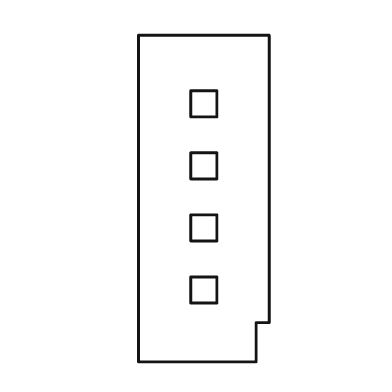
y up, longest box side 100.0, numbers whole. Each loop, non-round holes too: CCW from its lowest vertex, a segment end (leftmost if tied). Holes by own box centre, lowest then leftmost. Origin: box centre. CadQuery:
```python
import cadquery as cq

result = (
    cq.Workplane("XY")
    .moveTo(-20.0, -50.0)
    .lineTo(16.0, -50.0)
    .lineTo(16.0, -38.0)
    .lineTo(20.0, -38.0)
    .lineTo(20.0, 50.0)
    .lineTo(-20.0, 50.0)
    .close()
    .moveTo(-4.0, -32.0)
    .lineTo(4.0, -32.0)
    .lineTo(4.0, -24.0)
    .lineTo(-4.0, -24.0)
    .close()
    .moveTo(-4.0, -13.0)
    .lineTo(4.0, -13.0)
    .lineTo(4.0, -5.0)
    .lineTo(-4.0, -5.0)
    .close()
    .moveTo(-4.0, 6.0)
    .lineTo(4.0, 6.0)
    .lineTo(4.0, 14.0)
    .lineTo(-4.0, 14.0)
    .close()
    .moveTo(-4.0, 25.0)
    .lineTo(4.0, 25.0)
    .lineTo(4.0, 33.0)
    .lineTo(-4.0, 33.0)
    .close()
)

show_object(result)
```